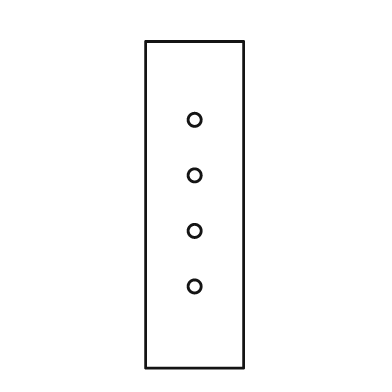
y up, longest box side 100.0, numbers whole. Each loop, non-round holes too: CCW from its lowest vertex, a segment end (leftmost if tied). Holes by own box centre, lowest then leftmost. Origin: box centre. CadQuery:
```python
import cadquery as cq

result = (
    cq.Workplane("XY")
    .moveTo(-15.0, -50.0)
    .lineTo(15.0, -50.0)
    .lineTo(15.0, 50.0)
    .lineTo(-15.0, 50.0)
    .close()
    .moveTo(0.0, -25.0)
    .circle(2.0)
    .moveTo(0.0, -8.0)
    .circle(2.0)
    .moveTo(0.0, 9.0)
    .circle(2.0)
    .moveTo(0.0, 26.0)
    .circle(2.0)
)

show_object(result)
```